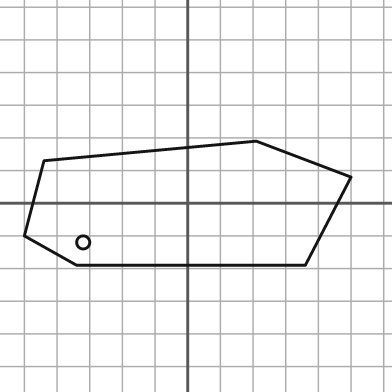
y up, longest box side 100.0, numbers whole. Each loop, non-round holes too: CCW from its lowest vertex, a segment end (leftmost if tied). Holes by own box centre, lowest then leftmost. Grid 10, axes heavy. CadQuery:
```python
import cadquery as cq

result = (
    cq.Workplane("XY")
    .moveTo(-34.0, -19.0)
    .lineTo(36.0, -19.0)
    .lineTo(50.0, 8.0)
    .lineTo(21.0, 19.0)
    .lineTo(-44.0, 13.0)
    .lineTo(-50.0, -10.0)
    .close()
    .moveTo(-32.0, -12.0)
    .circle(2.0)
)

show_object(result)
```